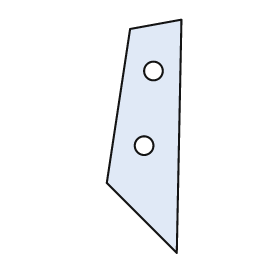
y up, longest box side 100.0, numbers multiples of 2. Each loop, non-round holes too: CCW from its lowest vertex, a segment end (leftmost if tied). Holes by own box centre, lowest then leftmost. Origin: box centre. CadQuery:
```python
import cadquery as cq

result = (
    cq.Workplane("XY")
    .moveTo(14.0, -50.0)
    .lineTo(16.0, 50.0)
    .lineTo(-6.0, 46.0)
    .lineTo(-16.0, -20.0)
    .close()
    .moveTo(0.0, -4.0)
    .circle(4.0)
    .moveTo(4.0, 28.0)
    .circle(4.0)
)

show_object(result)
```